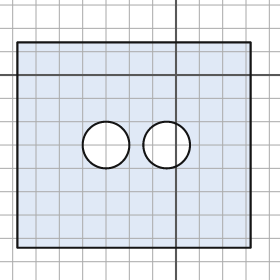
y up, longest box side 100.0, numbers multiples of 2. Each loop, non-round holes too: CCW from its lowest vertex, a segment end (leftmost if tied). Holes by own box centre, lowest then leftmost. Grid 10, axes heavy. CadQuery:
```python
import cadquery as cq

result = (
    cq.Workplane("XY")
    .moveTo(-68.0, -74.0)
    .lineTo(32.0, -74.0)
    .lineTo(32.0, 14.0)
    .lineTo(-68.0, 14.0)
    .close()
    .moveTo(-30.0, -30.0)
    .circle(10.0)
    .moveTo(-4.0, -30.0)
    .circle(10.0)
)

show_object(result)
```